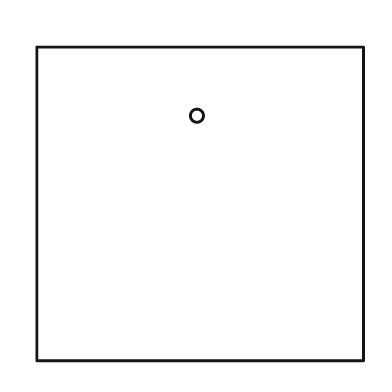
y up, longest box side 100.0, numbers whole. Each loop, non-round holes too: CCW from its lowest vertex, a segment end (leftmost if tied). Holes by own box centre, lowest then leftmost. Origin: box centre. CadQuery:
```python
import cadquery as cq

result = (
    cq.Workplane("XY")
    .moveTo(-50.0, -48.0)
    .lineTo(50.0, -48.0)
    .lineTo(50.0, 48.0)
    .lineTo(-50.0, 48.0)
    .close()
    .moveTo(-1.0, 27.0)
    .circle(2.0)
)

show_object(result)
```